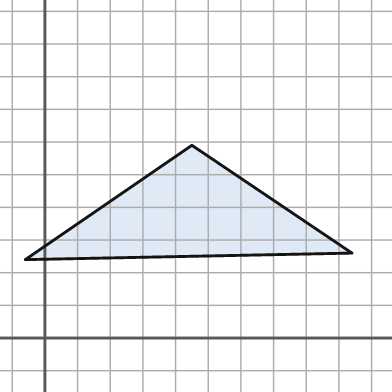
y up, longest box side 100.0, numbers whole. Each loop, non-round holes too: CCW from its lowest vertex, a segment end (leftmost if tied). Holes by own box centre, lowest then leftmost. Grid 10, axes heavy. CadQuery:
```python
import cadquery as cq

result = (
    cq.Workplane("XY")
    .moveTo(-6.0, 24.0)
    .lineTo(94.0, 26.0)
    .lineTo(45.0, 59.0)
    .close()
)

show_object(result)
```